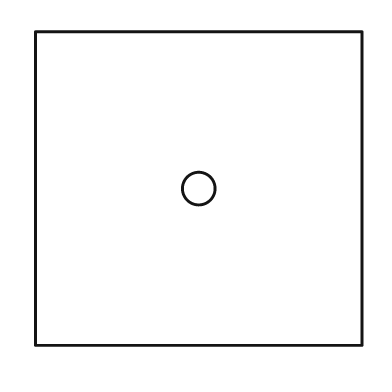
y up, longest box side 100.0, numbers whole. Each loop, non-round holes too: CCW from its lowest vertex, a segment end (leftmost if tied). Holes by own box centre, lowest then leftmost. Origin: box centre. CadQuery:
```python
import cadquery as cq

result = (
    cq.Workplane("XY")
    .moveTo(-50.0, -48.0)
    .lineTo(50.0, -48.0)
    .lineTo(50.0, 48.0)
    .lineTo(-50.0, 48.0)
    .close()
    .moveTo(0.0, 0.0)
    .circle(5.0)
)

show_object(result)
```